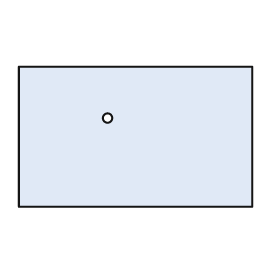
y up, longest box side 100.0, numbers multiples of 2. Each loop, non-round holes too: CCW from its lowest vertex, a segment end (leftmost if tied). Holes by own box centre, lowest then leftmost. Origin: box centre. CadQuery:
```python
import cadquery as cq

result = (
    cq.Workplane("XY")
    .moveTo(-50.0, -30.0)
    .lineTo(50.0, -30.0)
    .lineTo(50.0, 30.0)
    .lineTo(-50.0, 30.0)
    .close()
    .moveTo(-12.0, 8.0)
    .circle(2.0)
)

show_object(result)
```